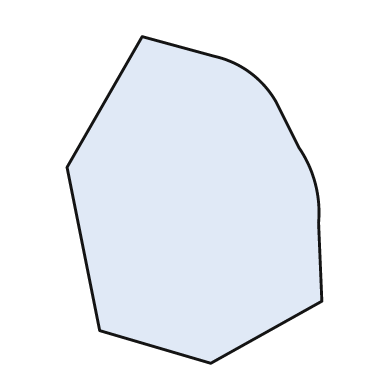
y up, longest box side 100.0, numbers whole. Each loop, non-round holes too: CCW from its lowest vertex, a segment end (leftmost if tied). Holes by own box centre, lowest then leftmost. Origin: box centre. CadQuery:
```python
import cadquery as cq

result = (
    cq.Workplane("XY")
    .moveTo(5.0, -50.0)
    .lineTo(39.0, -31.0)
    .lineTo(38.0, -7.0)
    .threePointArc((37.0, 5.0), (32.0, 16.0))
    .lineTo(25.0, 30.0)
    .threePointArc((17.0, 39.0), (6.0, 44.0))
    .lineTo(-16.0, 50.0)
    .lineTo(-39.0, 10.0)
    .lineTo(-29.0, -40.0)
    .close()
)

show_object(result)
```